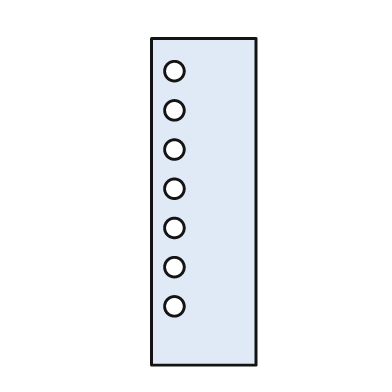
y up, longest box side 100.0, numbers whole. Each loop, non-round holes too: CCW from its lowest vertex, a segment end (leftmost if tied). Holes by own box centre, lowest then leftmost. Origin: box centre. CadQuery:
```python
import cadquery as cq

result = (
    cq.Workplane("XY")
    .moveTo(-16.0, -50.0)
    .lineTo(16.0, -50.0)
    .lineTo(16.0, 50.0)
    .lineTo(-16.0, 50.0)
    .close()
    .moveTo(-9.0, -32.0)
    .circle(3.0)
    .moveTo(-9.0, -20.0)
    .circle(3.0)
    .moveTo(-9.0, -8.0)
    .circle(3.0)
    .moveTo(-9.0, 4.0)
    .circle(3.0)
    .moveTo(-9.0, 16.0)
    .circle(3.0)
    .moveTo(-9.0, 28.0)
    .circle(3.0)
    .moveTo(-9.0, 40.0)
    .circle(3.0)
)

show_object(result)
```